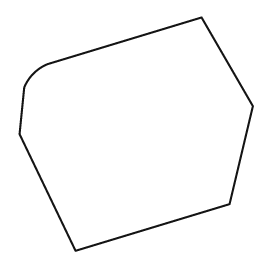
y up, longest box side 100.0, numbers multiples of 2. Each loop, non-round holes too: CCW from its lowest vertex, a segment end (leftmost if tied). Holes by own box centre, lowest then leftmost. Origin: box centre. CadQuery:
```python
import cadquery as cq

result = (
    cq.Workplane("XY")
    .moveTo(-26.0, -50.0)
    .lineTo(40.0, -30.0)
    .lineTo(50.0, 12.0)
    .lineTo(28.0, 50.0)
    .lineTo(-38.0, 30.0)
    .threePointArc((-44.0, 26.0), (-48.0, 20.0))
    .lineTo(-50.0, 0.0)
    .close()
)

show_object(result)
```